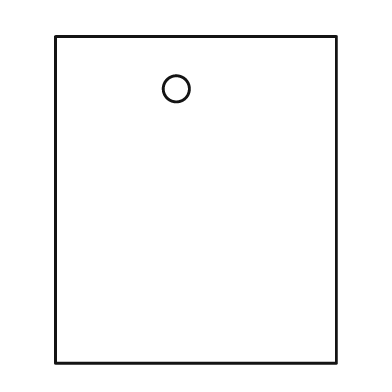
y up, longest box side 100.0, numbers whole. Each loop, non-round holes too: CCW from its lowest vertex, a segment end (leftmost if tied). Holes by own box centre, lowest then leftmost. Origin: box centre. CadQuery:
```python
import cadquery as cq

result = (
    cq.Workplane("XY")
    .moveTo(-43.0, -50.0)
    .lineTo(43.0, -50.0)
    .lineTo(43.0, 50.0)
    .lineTo(-43.0, 50.0)
    .close()
    .moveTo(-6.0, 34.0)
    .circle(4.0)
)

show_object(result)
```